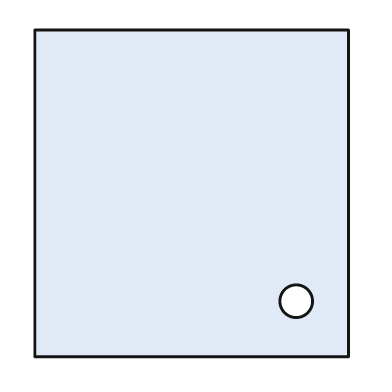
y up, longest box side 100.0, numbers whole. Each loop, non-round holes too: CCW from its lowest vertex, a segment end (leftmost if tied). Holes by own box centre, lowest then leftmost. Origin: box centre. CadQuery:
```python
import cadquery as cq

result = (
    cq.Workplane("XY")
    .moveTo(-48.0, -50.0)
    .lineTo(48.0, -50.0)
    .lineTo(48.0, 50.0)
    .lineTo(-48.0, 50.0)
    .close()
    .moveTo(32.0, -33.0)
    .circle(5.0)
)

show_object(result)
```